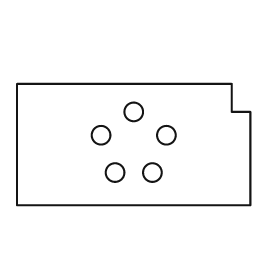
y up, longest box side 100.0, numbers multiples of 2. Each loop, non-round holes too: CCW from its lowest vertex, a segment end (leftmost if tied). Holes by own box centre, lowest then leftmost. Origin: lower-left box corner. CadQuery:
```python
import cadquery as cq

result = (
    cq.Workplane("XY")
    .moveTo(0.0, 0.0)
    .lineTo(100.0, 0.0)
    .lineTo(100.0, 40.0)
    .lineTo(92.0, 40.0)
    .lineTo(92.0, 52.0)
    .lineTo(0.0, 52.0)
    .close()
    .moveTo(42.0, 14.0)
    .circle(4.0)
    .moveTo(58.0, 14.0)
    .circle(4.0)
    .moveTo(36.0, 30.0)
    .circle(4.0)
    .moveTo(64.0, 30.0)
    .circle(4.0)
    .moveTo(50.0, 40.0)
    .circle(4.0)
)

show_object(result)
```